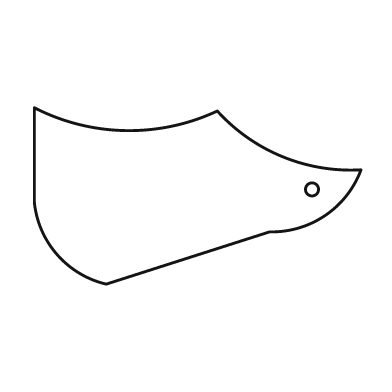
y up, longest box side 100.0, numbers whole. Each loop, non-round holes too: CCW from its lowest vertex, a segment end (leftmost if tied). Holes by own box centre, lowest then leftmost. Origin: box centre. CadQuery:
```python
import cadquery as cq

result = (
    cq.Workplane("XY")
    .moveTo(-28.0, -27.0)
    .lineTo(22.0, -11.0)
    .threePointArc((39.0, -6.0), (50.0, 8.0))
    .threePointArc((26.0, 12.0), (6.0, 26.0))
    .threePointArc((-22.0, 20.0), (-50.0, 27.0))
    .lineTo(-50.0, -2.0)
    .threePointArc((-43.0, -18.0), (-28.0, -27.0))
    .close()
    .moveTo(35.0, 2.0)
    .circle(2.0)
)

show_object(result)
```